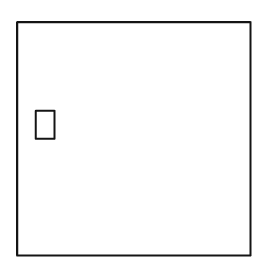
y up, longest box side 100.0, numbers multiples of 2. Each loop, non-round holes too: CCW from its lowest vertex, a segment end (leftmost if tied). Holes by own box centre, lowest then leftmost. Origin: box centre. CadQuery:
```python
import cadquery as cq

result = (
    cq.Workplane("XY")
    .moveTo(-50.0, -50.0)
    .lineTo(50.0, -50.0)
    .lineTo(50.0, 50.0)
    .lineTo(-50.0, 50.0)
    .close()
    .moveTo(-42.0, 0.0)
    .lineTo(-34.0, 0.0)
    .lineTo(-34.0, 12.0)
    .lineTo(-42.0, 12.0)
    .close()
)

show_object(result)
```